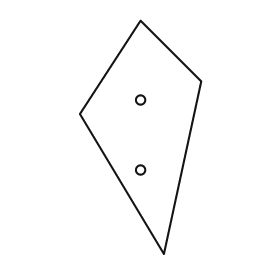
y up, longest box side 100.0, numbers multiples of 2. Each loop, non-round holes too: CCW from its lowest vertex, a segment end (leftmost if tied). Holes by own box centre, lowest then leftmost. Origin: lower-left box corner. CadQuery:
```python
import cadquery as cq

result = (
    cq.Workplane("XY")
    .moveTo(36.0, 0.0)
    .lineTo(52.0, 74.0)
    .lineTo(26.0, 100.0)
    .lineTo(0.0, 60.0)
    .close()
    .moveTo(26.0, 36.0)
    .circle(2.0)
    .moveTo(26.0, 66.0)
    .circle(2.0)
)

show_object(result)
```